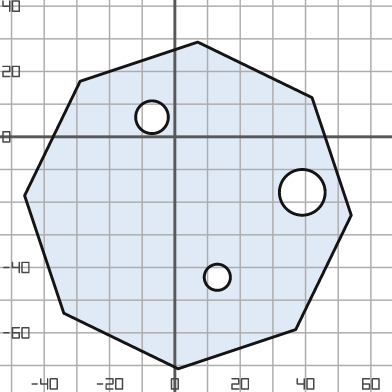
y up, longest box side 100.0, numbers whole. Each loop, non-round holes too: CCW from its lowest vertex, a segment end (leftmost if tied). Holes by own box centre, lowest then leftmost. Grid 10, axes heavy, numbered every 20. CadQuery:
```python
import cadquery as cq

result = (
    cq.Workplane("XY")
    .moveTo(1.0, -71.0)
    .lineTo(37.0, -59.0)
    .lineTo(54.0, -24.0)
    .lineTo(42.0, 12.0)
    .lineTo(7.0, 29.0)
    .lineTo(-29.0, 17.0)
    .lineTo(-46.0, -18.0)
    .lineTo(-34.0, -54.0)
    .close()
    .moveTo(13.0, -43.0)
    .circle(4.0)
    .moveTo(39.0, -17.0)
    .circle(7.0)
    .moveTo(-7.0, 6.0)
    .circle(5.0)
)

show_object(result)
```